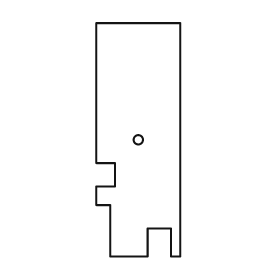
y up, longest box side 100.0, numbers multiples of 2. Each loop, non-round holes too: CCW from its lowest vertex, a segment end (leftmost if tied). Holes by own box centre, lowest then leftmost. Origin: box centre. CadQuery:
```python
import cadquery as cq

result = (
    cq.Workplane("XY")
    .moveTo(-12.0, -50.0)
    .lineTo(4.0, -50.0)
    .lineTo(4.0, -38.0)
    .lineTo(14.0, -38.0)
    .lineTo(14.0, -50.0)
    .lineTo(18.0, -50.0)
    .lineTo(18.0, 50.0)
    .lineTo(-18.0, 50.0)
    .lineTo(-18.0, -10.0)
    .lineTo(-10.0, -10.0)
    .lineTo(-10.0, -20.0)
    .lineTo(-18.0, -20.0)
    .lineTo(-18.0, -28.0)
    .lineTo(-12.0, -28.0)
    .close()
    .moveTo(0.0, 0.0)
    .circle(2.0)
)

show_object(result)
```